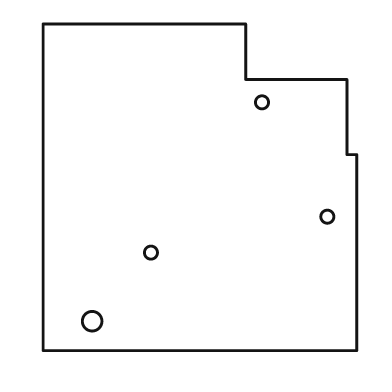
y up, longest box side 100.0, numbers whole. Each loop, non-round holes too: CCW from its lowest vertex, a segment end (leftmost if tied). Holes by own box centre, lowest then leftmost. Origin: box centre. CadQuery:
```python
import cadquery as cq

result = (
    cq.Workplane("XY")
    .moveTo(-48.0, -50.0)
    .lineTo(48.0, -50.0)
    .lineTo(48.0, 10.0)
    .lineTo(45.0, 10.0)
    .lineTo(45.0, 33.0)
    .lineTo(14.0, 33.0)
    .lineTo(14.0, 50.0)
    .lineTo(-48.0, 50.0)
    .close()
    .moveTo(-33.0, -41.0)
    .circle(3.0)
    .moveTo(-15.0, -20.0)
    .circle(2.0)
    .moveTo(39.0, -9.0)
    .circle(2.0)
    .moveTo(19.0, 26.0)
    .circle(2.0)
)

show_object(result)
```